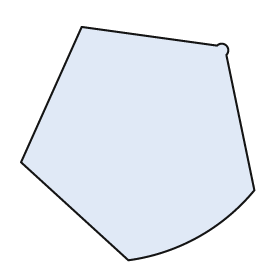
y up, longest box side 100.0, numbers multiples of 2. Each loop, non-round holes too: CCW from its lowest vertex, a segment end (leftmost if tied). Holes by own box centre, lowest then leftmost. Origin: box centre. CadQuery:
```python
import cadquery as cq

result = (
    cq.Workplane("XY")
    .moveTo(-4.0, -50.0)
    .threePointArc((26.0, -40.0), (50.0, -20.0))
    .lineTo(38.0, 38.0)
    .threePointArc((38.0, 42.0), (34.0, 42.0))
    .lineTo(-24.0, 50.0)
    .lineTo(-50.0, -8.0)
    .close()
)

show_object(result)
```